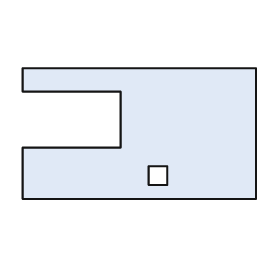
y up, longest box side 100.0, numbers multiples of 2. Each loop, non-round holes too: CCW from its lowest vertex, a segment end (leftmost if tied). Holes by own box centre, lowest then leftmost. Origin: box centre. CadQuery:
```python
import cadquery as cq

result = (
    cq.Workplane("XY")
    .moveTo(-50.0, -28.0)
    .lineTo(50.0, -28.0)
    .lineTo(50.0, 28.0)
    .lineTo(-50.0, 28.0)
    .lineTo(-50.0, 18.0)
    .lineTo(-8.0, 18.0)
    .lineTo(-8.0, -6.0)
    .lineTo(-50.0, -6.0)
    .close()
    .moveTo(4.0, -22.0)
    .lineTo(12.0, -22.0)
    .lineTo(12.0, -14.0)
    .lineTo(4.0, -14.0)
    .close()
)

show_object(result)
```